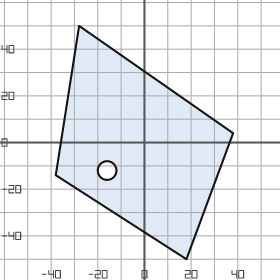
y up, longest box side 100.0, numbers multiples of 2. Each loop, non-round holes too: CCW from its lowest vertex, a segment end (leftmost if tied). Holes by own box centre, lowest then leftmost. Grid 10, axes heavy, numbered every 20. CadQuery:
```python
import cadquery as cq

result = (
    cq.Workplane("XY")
    .moveTo(18.0, -50.0)
    .lineTo(38.0, 4.0)
    .lineTo(-28.0, 50.0)
    .lineTo(-38.0, -14.0)
    .close()
    .moveTo(-16.0, -12.0)
    .circle(4.0)
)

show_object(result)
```